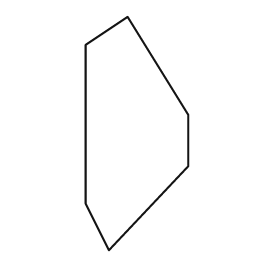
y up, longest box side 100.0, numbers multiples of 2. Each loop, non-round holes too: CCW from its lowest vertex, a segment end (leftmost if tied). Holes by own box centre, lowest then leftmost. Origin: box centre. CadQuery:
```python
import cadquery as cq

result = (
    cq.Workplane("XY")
    .moveTo(-12.0, -50.0)
    .lineTo(22.0, -14.0)
    .lineTo(22.0, 8.0)
    .lineTo(-4.0, 50.0)
    .lineTo(-22.0, 38.0)
    .lineTo(-22.0, -30.0)
    .close()
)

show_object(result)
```